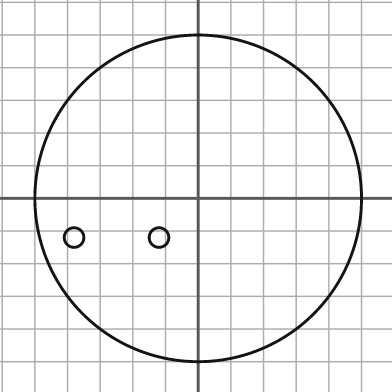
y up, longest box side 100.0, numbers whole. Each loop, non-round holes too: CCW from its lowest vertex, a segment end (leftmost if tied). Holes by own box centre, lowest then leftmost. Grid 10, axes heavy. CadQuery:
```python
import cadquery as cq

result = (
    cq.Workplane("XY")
    .moveTo(0.0, 0.0)
    .circle(50.0)
    .moveTo(-38.0, -12.0)
    .circle(3.0)
    .moveTo(-12.0, -12.0)
    .circle(3.0)
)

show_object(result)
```